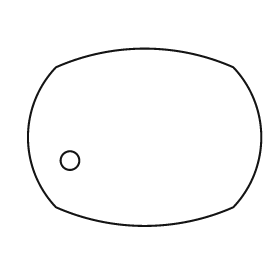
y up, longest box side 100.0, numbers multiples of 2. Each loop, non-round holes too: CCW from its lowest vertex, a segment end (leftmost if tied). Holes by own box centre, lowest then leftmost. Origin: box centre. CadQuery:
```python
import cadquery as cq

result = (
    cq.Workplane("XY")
    .moveTo(-38.0, -30.0)
    .threePointArc((0.0, -38.0), (38.0, -30.0))
    .threePointArc((50.0, 0.0), (38.0, 30.0))
    .threePointArc((0.0, 38.0), (-38.0, 30.0))
    .threePointArc((-50.0, 0.0), (-38.0, -30.0))
    .close()
    .moveTo(-32.0, -10.0)
    .circle(4.0)
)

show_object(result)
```